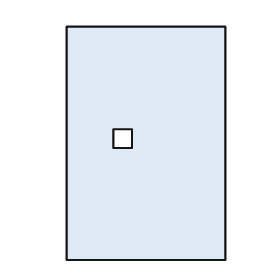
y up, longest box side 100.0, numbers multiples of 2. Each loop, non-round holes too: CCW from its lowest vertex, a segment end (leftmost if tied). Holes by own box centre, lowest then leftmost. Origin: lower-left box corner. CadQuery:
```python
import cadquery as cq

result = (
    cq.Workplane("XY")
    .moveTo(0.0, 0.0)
    .lineTo(68.0, 0.0)
    .lineTo(68.0, 100.0)
    .lineTo(0.0, 100.0)
    .close()
    .moveTo(20.0, 48.0)
    .lineTo(28.0, 48.0)
    .lineTo(28.0, 56.0)
    .lineTo(20.0, 56.0)
    .close()
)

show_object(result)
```